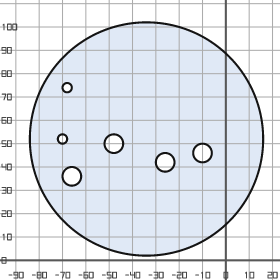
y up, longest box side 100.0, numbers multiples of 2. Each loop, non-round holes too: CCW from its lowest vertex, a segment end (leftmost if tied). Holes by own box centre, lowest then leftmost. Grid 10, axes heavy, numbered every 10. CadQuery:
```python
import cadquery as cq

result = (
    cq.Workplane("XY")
    .moveTo(-34.0, 52.0)
    .circle(50.0)
    .moveTo(-66.0, 36.0)
    .circle(4.0)
    .moveTo(-26.0, 42.0)
    .circle(4.0)
    .moveTo(-10.0, 46.0)
    .circle(4.0)
    .moveTo(-48.0, 50.0)
    .circle(4.0)
    .moveTo(-70.0, 52.0)
    .circle(2.0)
    .moveTo(-68.0, 74.0)
    .circle(2.0)
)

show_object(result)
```